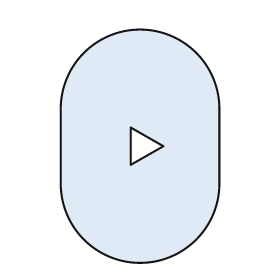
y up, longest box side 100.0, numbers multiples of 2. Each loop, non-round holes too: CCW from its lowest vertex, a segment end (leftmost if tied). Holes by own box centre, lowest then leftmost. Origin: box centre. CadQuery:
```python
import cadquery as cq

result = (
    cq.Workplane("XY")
    .moveTo(-34.0, -16.0)
    .threePointArc((0.0, -50.0), (34.0, -16.0))
    .lineTo(34.0, 16.0)
    .threePointArc((0.0, 50.0), (-34.0, 16.0))
    .close()
    .moveTo(-4.0, -8.0)
    .lineTo(10.0, 0.0)
    .lineTo(-4.0, 8.0)
    .close()
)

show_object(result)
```